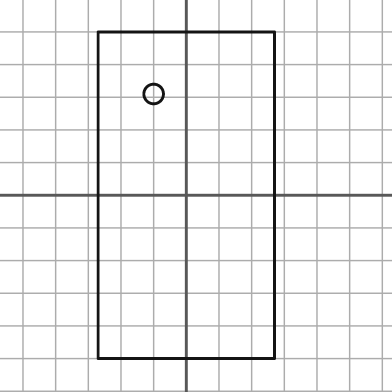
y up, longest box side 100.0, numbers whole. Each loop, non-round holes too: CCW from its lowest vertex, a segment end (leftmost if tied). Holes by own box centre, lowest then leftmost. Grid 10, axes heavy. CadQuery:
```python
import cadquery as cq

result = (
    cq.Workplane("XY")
    .moveTo(-27.0, -50.0)
    .lineTo(27.0, -50.0)
    .lineTo(27.0, 50.0)
    .lineTo(-27.0, 50.0)
    .close()
    .moveTo(-10.0, 31.0)
    .circle(3.0)
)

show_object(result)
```